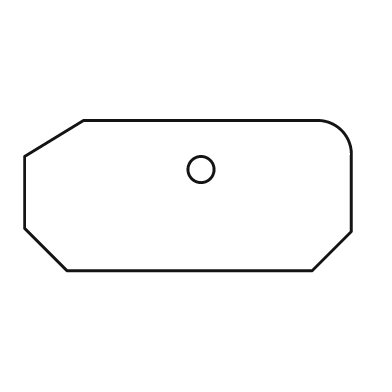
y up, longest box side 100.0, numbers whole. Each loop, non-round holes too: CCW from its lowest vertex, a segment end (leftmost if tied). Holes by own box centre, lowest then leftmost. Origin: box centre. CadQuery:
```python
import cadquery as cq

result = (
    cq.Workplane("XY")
    .moveTo(-37.0, -23.0)
    .lineTo(38.0, -23.0)
    .lineTo(50.0, -11.0)
    .lineTo(50.0, 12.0)
    .threePointArc((47.0, 20.0), (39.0, 23.0))
    .lineTo(-32.0, 23.0)
    .lineTo(-50.0, 12.0)
    .lineTo(-50.0, -10.0)
    .close()
    .moveTo(4.0, 8.0)
    .circle(4.0)
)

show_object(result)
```